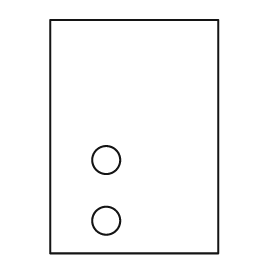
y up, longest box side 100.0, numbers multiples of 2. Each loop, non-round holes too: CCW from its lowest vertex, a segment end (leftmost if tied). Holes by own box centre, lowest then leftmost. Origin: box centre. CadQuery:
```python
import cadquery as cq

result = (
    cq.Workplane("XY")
    .moveTo(-36.0, -50.0)
    .lineTo(36.0, -50.0)
    .lineTo(36.0, 50.0)
    .lineTo(-36.0, 50.0)
    .close()
    .moveTo(-12.0, -36.0)
    .circle(6.0)
    .moveTo(-12.0, -10.0)
    .circle(6.0)
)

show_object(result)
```